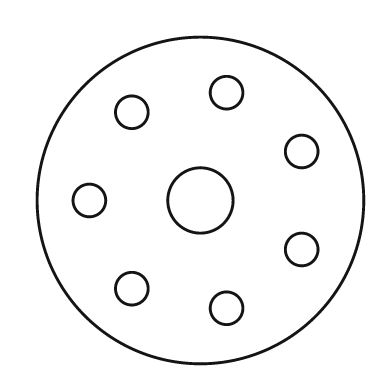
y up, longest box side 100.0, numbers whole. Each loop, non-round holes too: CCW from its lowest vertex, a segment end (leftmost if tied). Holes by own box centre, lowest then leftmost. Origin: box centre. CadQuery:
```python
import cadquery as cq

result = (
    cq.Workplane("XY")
    .moveTo(0.0, 0.0)
    .circle(50.0)
    .moveTo(8.0, -33.0)
    .circle(5.0)
    .moveTo(-21.0, -27.0)
    .circle(5.0)
    .moveTo(31.0, -15.0)
    .circle(5.0)
    .moveTo(-34.0, 0.0)
    .circle(5.0)
    .moveTo(0.0, 0.0)
    .circle(10.0)
    .moveTo(31.0, 15.0)
    .circle(5.0)
    .moveTo(-21.0, 27.0)
    .circle(5.0)
    .moveTo(8.0, 33.0)
    .circle(5.0)
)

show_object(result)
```